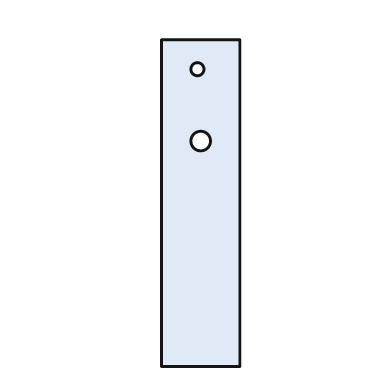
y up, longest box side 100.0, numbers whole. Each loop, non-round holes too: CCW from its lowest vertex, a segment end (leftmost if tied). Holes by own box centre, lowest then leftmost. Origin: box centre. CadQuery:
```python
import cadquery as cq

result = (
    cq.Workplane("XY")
    .moveTo(-12.0, -50.0)
    .lineTo(12.0, -50.0)
    .lineTo(12.0, 50.0)
    .lineTo(-12.0, 50.0)
    .close()
    .moveTo(0.0, 19.0)
    .circle(3.0)
    .moveTo(-1.0, 41.0)
    .circle(2.0)
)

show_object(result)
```